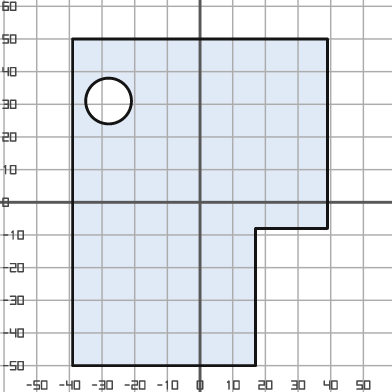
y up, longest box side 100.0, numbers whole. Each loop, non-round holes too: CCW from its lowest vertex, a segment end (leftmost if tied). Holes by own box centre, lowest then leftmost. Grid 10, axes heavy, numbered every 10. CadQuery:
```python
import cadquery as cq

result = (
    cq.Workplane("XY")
    .moveTo(-39.0, -50.0)
    .lineTo(17.0, -50.0)
    .lineTo(17.0, -8.0)
    .lineTo(39.0, -8.0)
    .lineTo(39.0, 50.0)
    .lineTo(-39.0, 50.0)
    .close()
    .moveTo(-28.0, 31.0)
    .circle(7.0)
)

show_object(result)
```